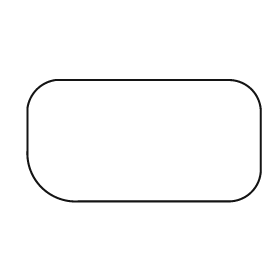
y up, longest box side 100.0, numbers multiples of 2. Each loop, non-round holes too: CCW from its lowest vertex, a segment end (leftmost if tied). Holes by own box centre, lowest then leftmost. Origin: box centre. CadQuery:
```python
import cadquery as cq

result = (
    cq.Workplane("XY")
    .moveTo(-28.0, -26.0)
    .lineTo(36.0, -26.0)
    .threePointArc((46.0, -22.0), (50.0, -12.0))
    .lineTo(50.0, 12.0)
    .threePointArc((46.0, 22.0), (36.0, 26.0))
    .lineTo(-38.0, 26.0)
    .threePointArc((-46.0, 22.0), (-50.0, 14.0))
    .lineTo(-50.0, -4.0)
    .threePointArc((-44.0, -20.0), (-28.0, -26.0))
    .close()
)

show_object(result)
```